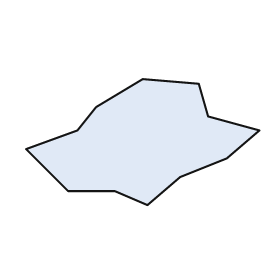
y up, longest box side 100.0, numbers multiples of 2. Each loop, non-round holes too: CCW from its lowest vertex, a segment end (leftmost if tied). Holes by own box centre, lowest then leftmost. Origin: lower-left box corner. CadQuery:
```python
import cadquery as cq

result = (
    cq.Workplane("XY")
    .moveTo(52.0, 0.0)
    .lineTo(66.0, 12.0)
    .lineTo(86.0, 20.0)
    .lineTo(100.0, 32.0)
    .lineTo(78.0, 38.0)
    .lineTo(74.0, 52.0)
    .lineTo(50.0, 54.0)
    .lineTo(30.0, 42.0)
    .lineTo(22.0, 32.0)
    .lineTo(0.0, 24.0)
    .lineTo(18.0, 6.0)
    .lineTo(38.0, 6.0)
    .close()
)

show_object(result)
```